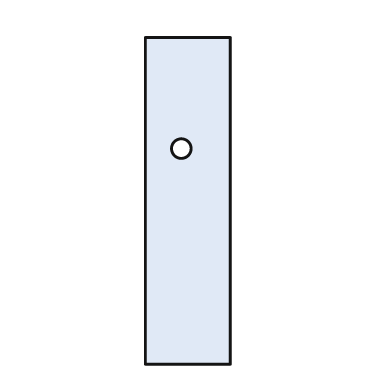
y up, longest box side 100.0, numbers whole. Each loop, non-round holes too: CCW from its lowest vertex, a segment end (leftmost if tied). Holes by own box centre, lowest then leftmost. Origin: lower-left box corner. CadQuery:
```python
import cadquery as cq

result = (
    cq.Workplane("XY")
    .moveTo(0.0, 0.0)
    .lineTo(26.0, 0.0)
    .lineTo(26.0, 100.0)
    .lineTo(0.0, 100.0)
    .close()
    .moveTo(11.0, 66.0)
    .circle(3.0)
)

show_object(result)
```